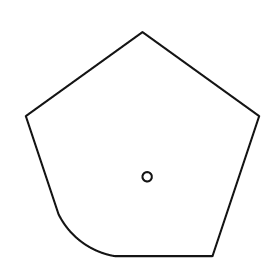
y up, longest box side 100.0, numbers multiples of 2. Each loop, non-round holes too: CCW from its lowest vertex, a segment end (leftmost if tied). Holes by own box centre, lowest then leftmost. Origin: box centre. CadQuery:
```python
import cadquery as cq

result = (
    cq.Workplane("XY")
    .moveTo(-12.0, -48.0)
    .lineTo(30.0, -48.0)
    .lineTo(50.0, 12.0)
    .lineTo(0.0, 48.0)
    .lineTo(-50.0, 12.0)
    .lineTo(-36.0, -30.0)
    .threePointArc((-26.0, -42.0), (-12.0, -48.0))
    .close()
    .moveTo(2.0, -14.0)
    .circle(2.0)
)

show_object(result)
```